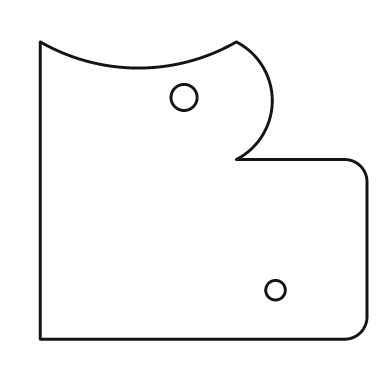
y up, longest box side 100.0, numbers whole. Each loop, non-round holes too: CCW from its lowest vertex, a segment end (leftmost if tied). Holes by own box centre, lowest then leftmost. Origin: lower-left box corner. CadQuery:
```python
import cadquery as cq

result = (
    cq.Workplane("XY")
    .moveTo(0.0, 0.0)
    .lineTo(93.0, 0.0)
    .threePointArc((98.0, 2.0), (100.0, 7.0))
    .lineTo(100.0, 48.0)
    .threePointArc((98.0, 53.0), (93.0, 55.0))
    .lineTo(60.0, 55.0)
    .threePointArc((71.0, 73.0), (60.0, 91.0))
    .threePointArc((30.0, 83.0), (0.0, 91.0))
    .close()
    .moveTo(72.0, 15.0)
    .circle(3.0)
    .moveTo(44.0, 74.0)
    .circle(4.0)
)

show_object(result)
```